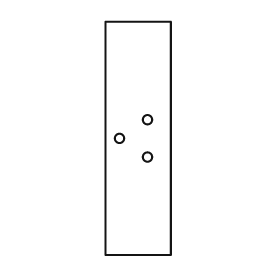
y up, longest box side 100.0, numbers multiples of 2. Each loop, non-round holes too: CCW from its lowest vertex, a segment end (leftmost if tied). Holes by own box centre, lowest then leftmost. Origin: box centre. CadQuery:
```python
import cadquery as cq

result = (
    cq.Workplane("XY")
    .moveTo(-14.0, -50.0)
    .lineTo(14.0, -50.0)
    .lineTo(14.0, 50.0)
    .lineTo(-14.0, 50.0)
    .close()
    .moveTo(4.0, -8.0)
    .circle(2.0)
    .moveTo(-8.0, 0.0)
    .circle(2.0)
    .moveTo(4.0, 8.0)
    .circle(2.0)
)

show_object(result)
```